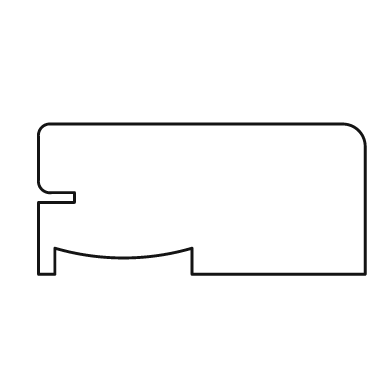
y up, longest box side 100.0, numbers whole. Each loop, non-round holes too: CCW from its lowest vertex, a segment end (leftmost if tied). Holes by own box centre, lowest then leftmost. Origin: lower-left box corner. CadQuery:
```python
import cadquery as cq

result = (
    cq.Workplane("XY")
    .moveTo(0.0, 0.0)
    .lineTo(5.0, 0.0)
    .lineTo(5.0, 8.0)
    .threePointArc((26.0, 5.0), (47.0, 8.0))
    .lineTo(47.0, 0.0)
    .lineTo(100.0, 0.0)
    .lineTo(100.0, 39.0)
    .threePointArc((98.0, 44.0), (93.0, 46.0))
    .lineTo(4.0, 46.0)
    .threePointArc((1.0, 45.0), (0.0, 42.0))
    .lineTo(0.0, 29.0)
    .threePointArc((1.0, 26.0), (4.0, 25.0))
    .lineTo(11.0, 25.0)
    .lineTo(11.0, 22.0)
    .lineTo(0.0, 22.0)
    .close()
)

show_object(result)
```